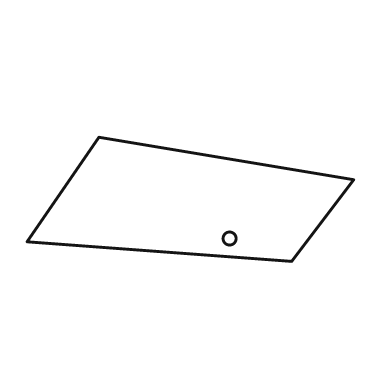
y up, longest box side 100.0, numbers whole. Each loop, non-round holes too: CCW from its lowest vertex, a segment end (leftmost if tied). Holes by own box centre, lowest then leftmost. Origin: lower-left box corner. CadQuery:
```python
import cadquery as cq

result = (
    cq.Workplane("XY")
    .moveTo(81.0, 0.0)
    .lineTo(100.0, 25.0)
    .lineTo(22.0, 38.0)
    .lineTo(0.0, 6.0)
    .close()
    .moveTo(62.0, 7.0)
    .circle(2.0)
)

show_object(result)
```